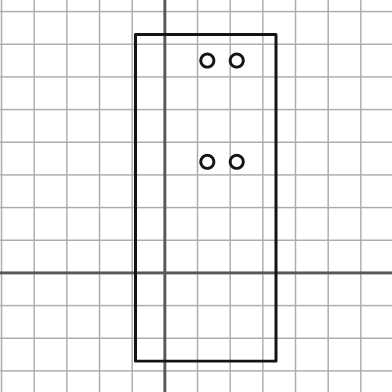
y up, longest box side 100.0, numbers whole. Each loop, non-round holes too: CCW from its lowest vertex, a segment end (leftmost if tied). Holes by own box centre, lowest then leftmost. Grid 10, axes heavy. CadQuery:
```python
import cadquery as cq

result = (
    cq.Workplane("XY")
    .moveTo(-9.0, -27.0)
    .lineTo(34.0, -27.0)
    .lineTo(34.0, 73.0)
    .lineTo(-9.0, 73.0)
    .close()
    .moveTo(13.0, 34.0)
    .circle(2.0)
    .moveTo(22.0, 34.0)
    .circle(2.0)
    .moveTo(13.0, 65.0)
    .circle(2.0)
    .moveTo(22.0, 65.0)
    .circle(2.0)
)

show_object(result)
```